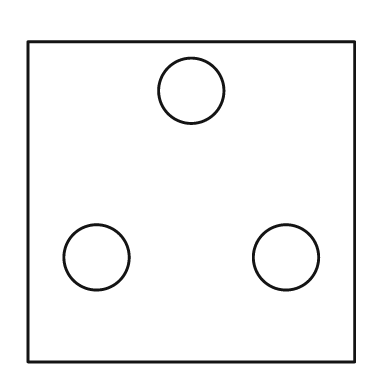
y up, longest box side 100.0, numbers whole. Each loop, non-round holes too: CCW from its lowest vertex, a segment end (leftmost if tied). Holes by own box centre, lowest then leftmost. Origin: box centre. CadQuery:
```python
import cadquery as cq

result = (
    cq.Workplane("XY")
    .moveTo(-50.0, -49.0)
    .lineTo(50.0, -49.0)
    .lineTo(50.0, 49.0)
    .lineTo(-50.0, 49.0)
    .close()
    .moveTo(-29.0, -17.0)
    .circle(10.0)
    .moveTo(29.0, -17.0)
    .circle(10.0)
    .moveTo(0.0, 34.0)
    .circle(10.0)
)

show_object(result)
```